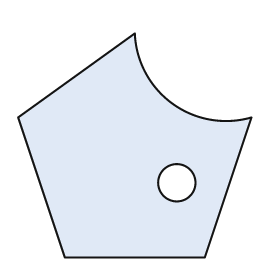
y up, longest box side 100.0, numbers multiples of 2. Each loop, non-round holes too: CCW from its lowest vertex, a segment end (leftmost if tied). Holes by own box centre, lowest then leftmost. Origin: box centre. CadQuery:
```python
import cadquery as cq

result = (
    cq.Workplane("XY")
    .moveTo(-30.0, -48.0)
    .lineTo(30.0, -48.0)
    .lineTo(50.0, 12.0)
    .threePointArc((16.0, 18.0), (0.0, 48.0))
    .lineTo(-50.0, 12.0)
    .close()
    .moveTo(18.0, -16.0)
    .circle(8.0)
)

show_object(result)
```